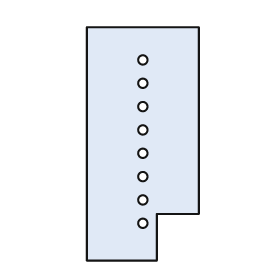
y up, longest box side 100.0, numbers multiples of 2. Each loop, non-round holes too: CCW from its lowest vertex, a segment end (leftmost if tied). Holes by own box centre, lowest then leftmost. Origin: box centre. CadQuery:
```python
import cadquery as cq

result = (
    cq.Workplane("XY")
    .moveTo(-24.0, -50.0)
    .lineTo(6.0, -50.0)
    .lineTo(6.0, -30.0)
    .lineTo(24.0, -30.0)
    .lineTo(24.0, 50.0)
    .lineTo(-24.0, 50.0)
    .close()
    .moveTo(0.0, -34.0)
    .circle(2.0)
    .moveTo(0.0, -24.0)
    .circle(2.0)
    .moveTo(0.0, -14.0)
    .circle(2.0)
    .moveTo(0.0, -4.0)
    .circle(2.0)
    .moveTo(0.0, 6.0)
    .circle(2.0)
    .moveTo(0.0, 16.0)
    .circle(2.0)
    .moveTo(0.0, 26.0)
    .circle(2.0)
    .moveTo(0.0, 36.0)
    .circle(2.0)
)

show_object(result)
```